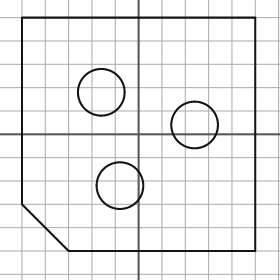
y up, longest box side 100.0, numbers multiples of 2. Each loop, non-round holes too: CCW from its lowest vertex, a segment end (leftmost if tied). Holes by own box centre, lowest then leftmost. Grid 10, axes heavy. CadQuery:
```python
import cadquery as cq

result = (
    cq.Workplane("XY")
    .moveTo(-30.0, -50.0)
    .lineTo(50.0, -50.0)
    .lineTo(50.0, 50.0)
    .lineTo(-50.0, 50.0)
    .lineTo(-50.0, -30.0)
    .close()
    .moveTo(-8.0, -22.0)
    .circle(10.0)
    .moveTo(24.0, 4.0)
    .circle(10.0)
    .moveTo(-16.0, 18.0)
    .circle(10.0)
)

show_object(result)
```